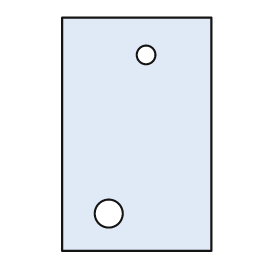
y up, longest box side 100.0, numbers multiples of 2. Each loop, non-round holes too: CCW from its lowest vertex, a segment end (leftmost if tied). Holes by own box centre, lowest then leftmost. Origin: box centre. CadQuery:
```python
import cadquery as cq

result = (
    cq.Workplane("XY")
    .moveTo(-32.0, -50.0)
    .lineTo(32.0, -50.0)
    .lineTo(32.0, 50.0)
    .lineTo(-32.0, 50.0)
    .close()
    .moveTo(-12.0, -34.0)
    .circle(6.0)
    .moveTo(4.0, 34.0)
    .circle(4.0)
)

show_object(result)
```